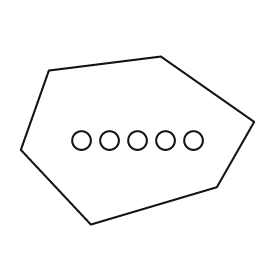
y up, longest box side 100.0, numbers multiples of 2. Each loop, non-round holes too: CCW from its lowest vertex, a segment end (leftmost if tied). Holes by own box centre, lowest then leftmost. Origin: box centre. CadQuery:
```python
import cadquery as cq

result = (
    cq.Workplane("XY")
    .moveTo(-20.0, -36.0)
    .lineTo(34.0, -20.0)
    .lineTo(50.0, 8.0)
    .lineTo(10.0, 36.0)
    .lineTo(-38.0, 30.0)
    .lineTo(-50.0, -4.0)
    .close()
    .moveTo(-24.0, 0.0)
    .circle(4.0)
    .moveTo(-12.0, 0.0)
    .circle(4.0)
    .moveTo(0.0, 0.0)
    .circle(4.0)
    .moveTo(12.0, 0.0)
    .circle(4.0)
    .moveTo(24.0, 0.0)
    .circle(4.0)
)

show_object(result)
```